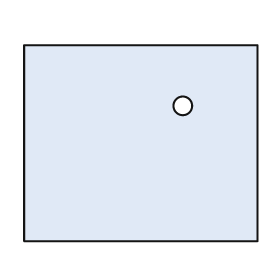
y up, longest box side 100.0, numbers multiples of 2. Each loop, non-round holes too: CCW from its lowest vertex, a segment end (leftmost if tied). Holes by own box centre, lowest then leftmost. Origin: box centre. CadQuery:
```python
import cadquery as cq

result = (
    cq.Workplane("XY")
    .moveTo(-50.0, -42.0)
    .lineTo(50.0, -42.0)
    .lineTo(50.0, 42.0)
    .lineTo(-50.0, 42.0)
    .close()
    .moveTo(18.0, 16.0)
    .circle(4.0)
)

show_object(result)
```